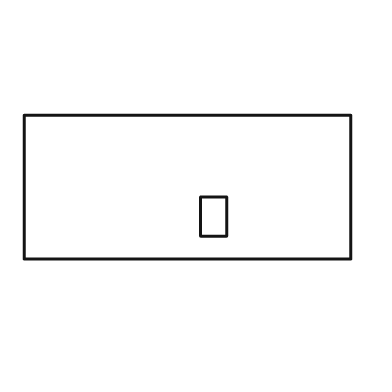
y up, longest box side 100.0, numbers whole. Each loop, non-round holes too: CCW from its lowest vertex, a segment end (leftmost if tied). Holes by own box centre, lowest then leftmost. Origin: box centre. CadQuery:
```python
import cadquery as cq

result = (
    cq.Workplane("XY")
    .moveTo(-50.0, -22.0)
    .lineTo(50.0, -22.0)
    .lineTo(50.0, 22.0)
    .lineTo(-50.0, 22.0)
    .close()
    .moveTo(4.0, -15.0)
    .lineTo(12.0, -15.0)
    .lineTo(12.0, -3.0)
    .lineTo(4.0, -3.0)
    .close()
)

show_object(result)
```